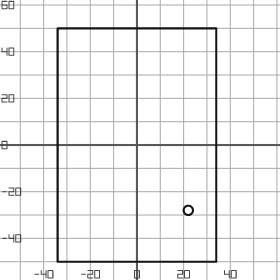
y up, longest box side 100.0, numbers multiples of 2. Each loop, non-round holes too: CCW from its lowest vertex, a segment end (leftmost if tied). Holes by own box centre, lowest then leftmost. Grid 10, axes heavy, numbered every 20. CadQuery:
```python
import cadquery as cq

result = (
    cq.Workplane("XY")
    .moveTo(-34.0, -50.0)
    .lineTo(34.0, -50.0)
    .lineTo(34.0, 50.0)
    .lineTo(-34.0, 50.0)
    .close()
    .moveTo(22.0, -28.0)
    .circle(2.0)
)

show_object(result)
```